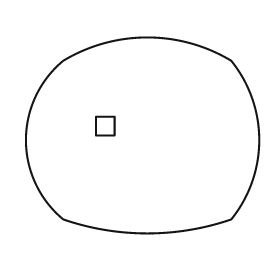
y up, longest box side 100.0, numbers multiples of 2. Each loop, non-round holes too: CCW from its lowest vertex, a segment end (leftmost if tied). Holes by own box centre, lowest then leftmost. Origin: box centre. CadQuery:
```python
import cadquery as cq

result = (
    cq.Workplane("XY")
    .moveTo(-34.0, -36.0)
    .threePointArc((2.0, -42.0), (38.0, -36.0))
    .threePointArc((50.0, -2.0), (38.0, 32.0))
    .threePointArc((2.0, 42.0), (-34.0, 32.0))
    .threePointArc((-50.0, -2.0), (-34.0, -36.0))
    .close()
    .moveTo(-20.0, 0.0)
    .lineTo(-12.0, 0.0)
    .lineTo(-12.0, 8.0)
    .lineTo(-20.0, 8.0)
    .close()
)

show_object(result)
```